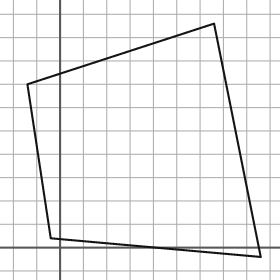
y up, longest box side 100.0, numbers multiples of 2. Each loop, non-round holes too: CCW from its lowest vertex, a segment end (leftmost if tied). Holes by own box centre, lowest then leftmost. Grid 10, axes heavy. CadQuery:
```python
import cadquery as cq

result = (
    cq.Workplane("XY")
    .moveTo(86.0, -4.0)
    .lineTo(66.0, 96.0)
    .lineTo(-14.0, 70.0)
    .lineTo(-4.0, 4.0)
    .close()
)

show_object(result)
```